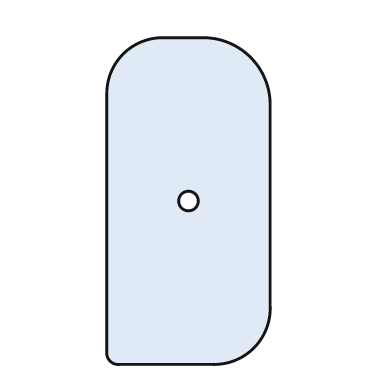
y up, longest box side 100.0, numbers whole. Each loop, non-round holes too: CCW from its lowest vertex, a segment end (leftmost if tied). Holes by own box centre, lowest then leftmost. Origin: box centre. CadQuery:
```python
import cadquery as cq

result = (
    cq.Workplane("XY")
    .moveTo(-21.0, -50.0)
    .lineTo(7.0, -50.0)
    .threePointArc((20.0, -45.0), (25.0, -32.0))
    .lineTo(25.0, 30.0)
    .threePointArc((19.0, 44.0), (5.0, 50.0))
    .lineTo(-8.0, 50.0)
    .threePointArc((-20.0, 45.0), (-25.0, 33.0))
    .lineTo(-25.0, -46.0)
    .threePointArc((-24.0, -49.0), (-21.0, -50.0))
    .close()
    .moveTo(0.0, 0.0)
    .circle(3.0)
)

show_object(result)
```